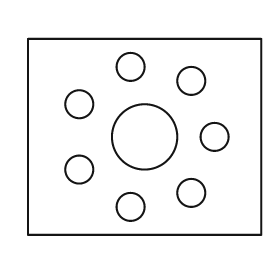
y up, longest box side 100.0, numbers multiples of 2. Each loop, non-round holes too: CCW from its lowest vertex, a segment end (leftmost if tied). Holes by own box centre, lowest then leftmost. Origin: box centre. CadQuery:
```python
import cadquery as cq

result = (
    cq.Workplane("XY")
    .moveTo(-50.0, -42.0)
    .lineTo(50.0, -42.0)
    .lineTo(50.0, 42.0)
    .lineTo(-50.0, 42.0)
    .close()
    .moveTo(-6.0, -30.0)
    .circle(6.0)
    .moveTo(20.0, -24.0)
    .circle(6.0)
    .moveTo(-28.0, -14.0)
    .circle(6.0)
    .moveTo(0.0, 0.0)
    .circle(14.0)
    .moveTo(30.0, 0.0)
    .circle(6.0)
    .moveTo(-28.0, 14.0)
    .circle(6.0)
    .moveTo(20.0, 24.0)
    .circle(6.0)
    .moveTo(-6.0, 30.0)
    .circle(6.0)
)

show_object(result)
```